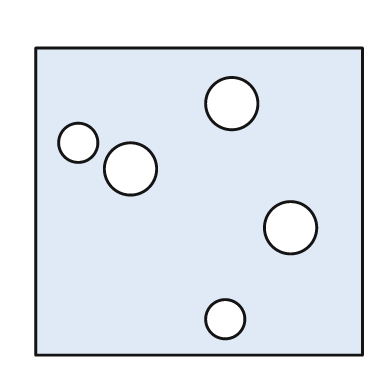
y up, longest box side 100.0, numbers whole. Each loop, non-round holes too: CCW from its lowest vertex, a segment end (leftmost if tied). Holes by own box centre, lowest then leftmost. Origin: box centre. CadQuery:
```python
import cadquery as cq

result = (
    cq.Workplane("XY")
    .moveTo(-50.0, -47.0)
    .lineTo(50.0, -47.0)
    .lineTo(50.0, 47.0)
    .lineTo(-50.0, 47.0)
    .close()
    .moveTo(8.0, -36.0)
    .circle(6.0)
    .moveTo(28.0, -8.0)
    .circle(8.0)
    .moveTo(-21.0, 10.0)
    .circle(8.0)
    .moveTo(-37.0, 18.0)
    .circle(6.0)
    .moveTo(10.0, 30.0)
    .circle(8.0)
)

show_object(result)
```